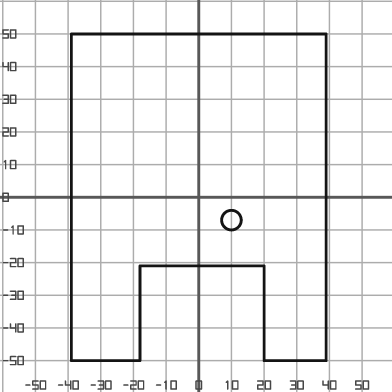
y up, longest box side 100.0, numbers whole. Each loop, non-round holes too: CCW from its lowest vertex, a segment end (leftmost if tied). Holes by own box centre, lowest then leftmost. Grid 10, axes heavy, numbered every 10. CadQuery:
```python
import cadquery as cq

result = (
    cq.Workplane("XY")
    .moveTo(-39.0, -50.0)
    .lineTo(-18.0, -50.0)
    .lineTo(-18.0, -21.0)
    .lineTo(20.0, -21.0)
    .lineTo(20.0, -50.0)
    .lineTo(39.0, -50.0)
    .lineTo(39.0, 50.0)
    .lineTo(-39.0, 50.0)
    .close()
    .moveTo(10.0, -7.0)
    .circle(3.0)
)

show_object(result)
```